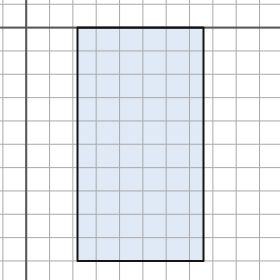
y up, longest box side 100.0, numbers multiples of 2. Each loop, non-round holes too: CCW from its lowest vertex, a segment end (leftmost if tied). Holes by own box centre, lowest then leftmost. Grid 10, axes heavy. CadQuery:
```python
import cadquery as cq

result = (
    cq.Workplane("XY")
    .moveTo(22.0, -100.0)
    .lineTo(76.0, -100.0)
    .lineTo(76.0, 0.0)
    .lineTo(22.0, 0.0)
    .close()
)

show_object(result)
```